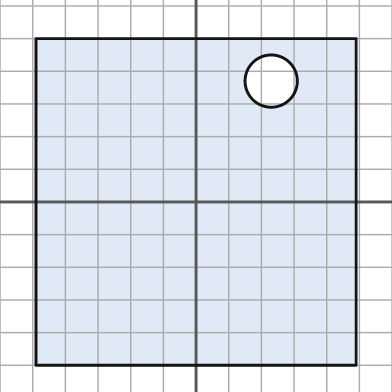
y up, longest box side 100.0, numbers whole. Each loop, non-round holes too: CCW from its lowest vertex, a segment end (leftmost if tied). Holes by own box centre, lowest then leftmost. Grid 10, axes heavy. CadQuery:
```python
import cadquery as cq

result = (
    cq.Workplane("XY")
    .moveTo(-49.0, -50.0)
    .lineTo(49.0, -50.0)
    .lineTo(49.0, 50.0)
    .lineTo(-49.0, 50.0)
    .close()
    .moveTo(23.0, 37.0)
    .circle(8.0)
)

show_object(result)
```